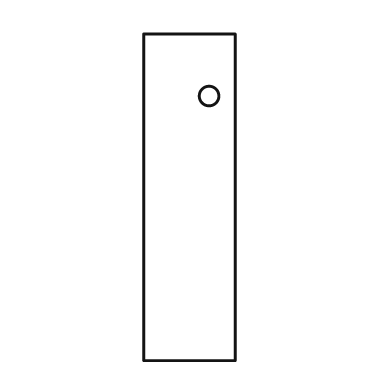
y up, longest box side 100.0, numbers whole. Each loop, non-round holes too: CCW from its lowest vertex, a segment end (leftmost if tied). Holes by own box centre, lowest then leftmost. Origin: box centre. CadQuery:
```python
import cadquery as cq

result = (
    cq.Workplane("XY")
    .moveTo(-14.0, -50.0)
    .lineTo(14.0, -50.0)
    .lineTo(14.0, 50.0)
    .lineTo(-14.0, 50.0)
    .close()
    .moveTo(6.0, 31.0)
    .circle(3.0)
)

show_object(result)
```